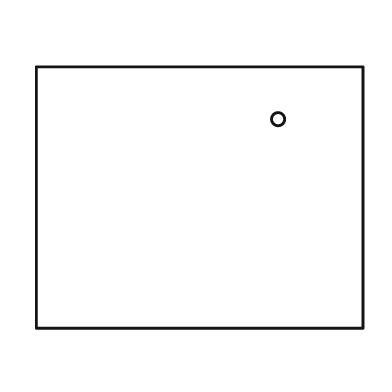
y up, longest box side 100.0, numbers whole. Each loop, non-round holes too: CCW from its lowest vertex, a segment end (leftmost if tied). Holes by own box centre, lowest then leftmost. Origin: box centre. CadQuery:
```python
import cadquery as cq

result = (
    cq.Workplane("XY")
    .moveTo(-50.0, -40.0)
    .lineTo(50.0, -40.0)
    .lineTo(50.0, 40.0)
    .lineTo(-50.0, 40.0)
    .close()
    .moveTo(24.0, 24.0)
    .circle(2.0)
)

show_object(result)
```